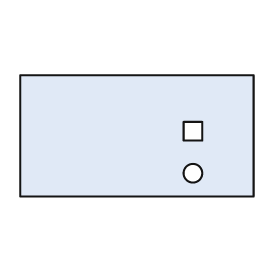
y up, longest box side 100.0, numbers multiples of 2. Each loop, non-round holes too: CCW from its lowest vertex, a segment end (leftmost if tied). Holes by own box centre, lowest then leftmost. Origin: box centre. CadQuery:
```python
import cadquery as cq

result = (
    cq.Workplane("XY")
    .moveTo(-50.0, -26.0)
    .lineTo(50.0, -26.0)
    .lineTo(50.0, 26.0)
    .lineTo(-50.0, 26.0)
    .close()
    .moveTo(24.0, -16.0)
    .circle(4.0)
    .moveTo(20.0, -2.0)
    .lineTo(28.0, -2.0)
    .lineTo(28.0, 6.0)
    .lineTo(20.0, 6.0)
    .close()
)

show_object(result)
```